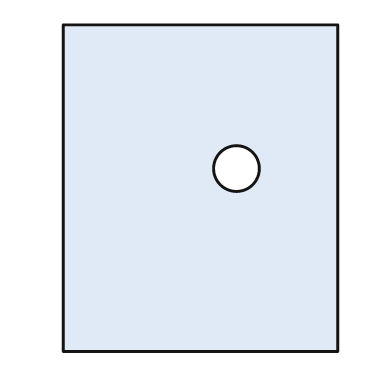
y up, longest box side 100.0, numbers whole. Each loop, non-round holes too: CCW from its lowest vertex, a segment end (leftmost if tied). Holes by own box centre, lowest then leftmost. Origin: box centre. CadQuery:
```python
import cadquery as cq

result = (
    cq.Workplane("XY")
    .moveTo(-42.0, -50.0)
    .lineTo(42.0, -50.0)
    .lineTo(42.0, 50.0)
    .lineTo(-42.0, 50.0)
    .close()
    .moveTo(11.0, 6.0)
    .circle(7.0)
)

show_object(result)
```